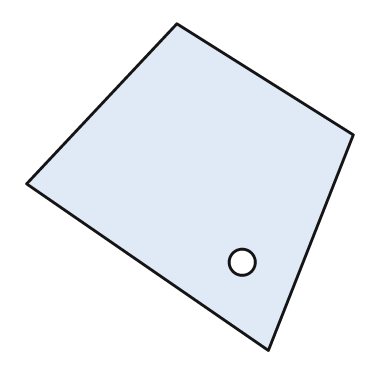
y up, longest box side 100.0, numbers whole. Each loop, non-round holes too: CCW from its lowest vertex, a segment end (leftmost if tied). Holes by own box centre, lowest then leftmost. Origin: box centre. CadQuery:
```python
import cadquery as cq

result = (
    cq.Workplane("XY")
    .moveTo(24.0, -50.0)
    .lineTo(50.0, 16.0)
    .lineTo(-4.0, 50.0)
    .lineTo(-50.0, 1.0)
    .close()
    .moveTo(16.0, -23.0)
    .circle(4.0)
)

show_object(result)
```